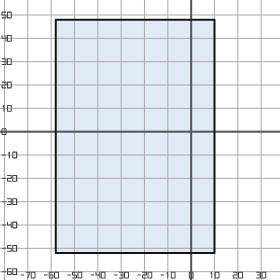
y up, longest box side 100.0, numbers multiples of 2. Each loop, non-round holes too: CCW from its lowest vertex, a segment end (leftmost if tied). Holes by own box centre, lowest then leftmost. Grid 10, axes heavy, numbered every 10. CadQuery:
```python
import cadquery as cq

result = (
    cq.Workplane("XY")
    .moveTo(-58.0, -52.0)
    .lineTo(10.0, -52.0)
    .lineTo(10.0, 48.0)
    .lineTo(-58.0, 48.0)
    .close()
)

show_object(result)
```